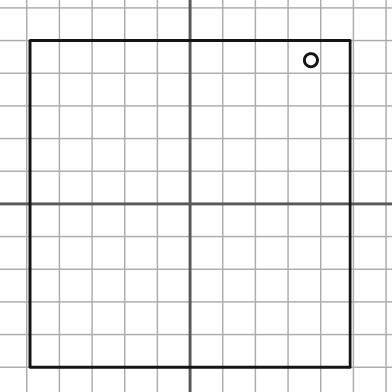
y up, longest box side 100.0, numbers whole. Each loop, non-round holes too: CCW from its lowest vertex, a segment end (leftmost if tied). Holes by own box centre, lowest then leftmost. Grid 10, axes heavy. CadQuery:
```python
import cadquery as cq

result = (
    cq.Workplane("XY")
    .moveTo(-49.0, -50.0)
    .lineTo(49.0, -50.0)
    .lineTo(49.0, 50.0)
    .lineTo(-49.0, 50.0)
    .close()
    .moveTo(37.0, 44.0)
    .circle(2.0)
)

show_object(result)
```